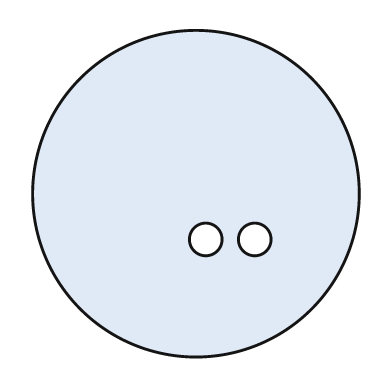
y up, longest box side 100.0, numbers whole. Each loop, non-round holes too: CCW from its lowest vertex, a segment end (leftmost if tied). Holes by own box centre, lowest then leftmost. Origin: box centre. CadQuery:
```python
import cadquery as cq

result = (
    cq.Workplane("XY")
    .moveTo(0.0, 0.0)
    .circle(50.0)
    .moveTo(3.0, -14.0)
    .circle(5.0)
    .moveTo(18.0, -14.0)
    .circle(5.0)
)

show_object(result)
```